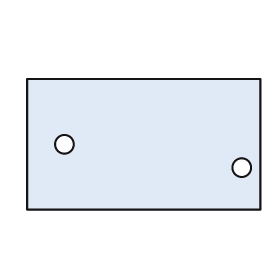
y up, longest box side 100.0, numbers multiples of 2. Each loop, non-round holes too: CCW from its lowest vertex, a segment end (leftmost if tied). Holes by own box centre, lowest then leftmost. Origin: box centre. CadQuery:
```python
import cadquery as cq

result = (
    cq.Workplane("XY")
    .moveTo(-50.0, -28.0)
    .lineTo(50.0, -28.0)
    .lineTo(50.0, 28.0)
    .lineTo(-50.0, 28.0)
    .close()
    .moveTo(42.0, -10.0)
    .circle(4.0)
    .moveTo(-34.0, 0.0)
    .circle(4.0)
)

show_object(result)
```